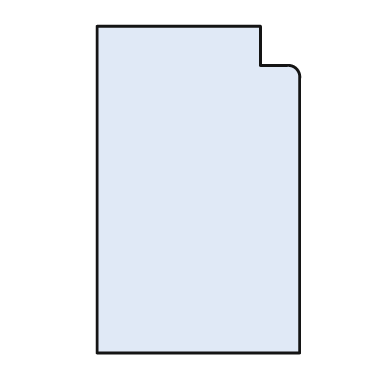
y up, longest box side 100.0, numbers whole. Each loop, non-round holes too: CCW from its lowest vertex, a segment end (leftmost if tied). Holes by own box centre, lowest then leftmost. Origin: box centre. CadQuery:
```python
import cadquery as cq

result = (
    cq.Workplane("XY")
    .moveTo(-31.0, -50.0)
    .lineTo(31.0, -50.0)
    .lineTo(31.0, 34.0)
    .threePointArc((30.0, 37.0), (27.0, 38.0))
    .lineTo(19.0, 38.0)
    .lineTo(19.0, 50.0)
    .lineTo(-31.0, 50.0)
    .close()
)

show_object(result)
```